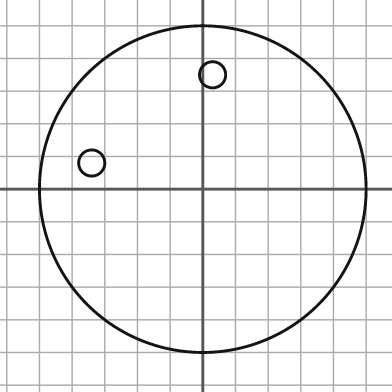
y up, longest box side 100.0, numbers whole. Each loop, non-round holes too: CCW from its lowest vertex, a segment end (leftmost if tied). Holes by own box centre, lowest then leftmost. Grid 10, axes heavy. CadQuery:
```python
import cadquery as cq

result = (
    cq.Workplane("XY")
    .moveTo(0.0, 0.0)
    .circle(50.0)
    .moveTo(-34.0, 8.0)
    .circle(4.0)
    .moveTo(3.0, 35.0)
    .circle(4.0)
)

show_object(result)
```